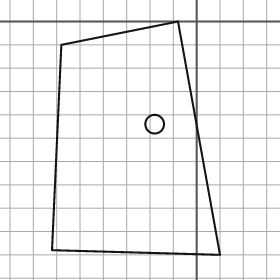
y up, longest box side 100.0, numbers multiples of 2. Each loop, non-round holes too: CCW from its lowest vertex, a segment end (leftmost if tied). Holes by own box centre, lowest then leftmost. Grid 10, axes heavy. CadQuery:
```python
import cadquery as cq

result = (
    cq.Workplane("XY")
    .moveTo(10.0, -100.0)
    .lineTo(-8.0, 0.0)
    .lineTo(-58.0, -10.0)
    .lineTo(-62.0, -98.0)
    .close()
    .moveTo(-18.0, -44.0)
    .circle(4.0)
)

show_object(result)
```